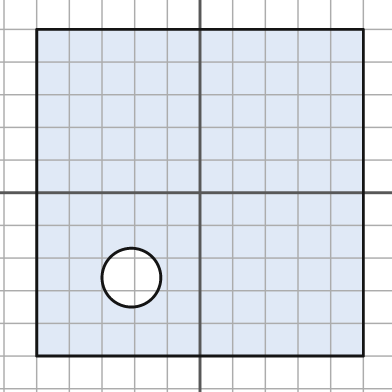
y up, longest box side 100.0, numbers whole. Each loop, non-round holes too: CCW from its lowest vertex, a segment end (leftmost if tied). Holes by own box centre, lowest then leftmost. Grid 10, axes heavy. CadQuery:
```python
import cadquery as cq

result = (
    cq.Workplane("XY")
    .moveTo(-50.0, -50.0)
    .lineTo(50.0, -50.0)
    .lineTo(50.0, 50.0)
    .lineTo(-50.0, 50.0)
    .close()
    .moveTo(-21.0, -26.0)
    .circle(9.0)
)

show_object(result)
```